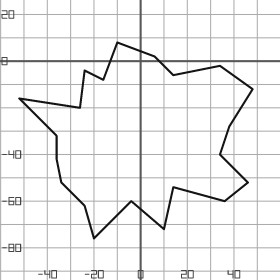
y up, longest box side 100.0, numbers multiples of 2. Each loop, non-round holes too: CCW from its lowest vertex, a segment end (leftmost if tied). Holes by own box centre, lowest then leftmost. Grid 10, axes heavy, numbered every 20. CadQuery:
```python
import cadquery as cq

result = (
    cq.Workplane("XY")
    .moveTo(-20.0, -76.0)
    .lineTo(-4.0, -60.0)
    .lineTo(10.0, -72.0)
    .lineTo(14.0, -54.0)
    .lineTo(36.0, -60.0)
    .lineTo(46.0, -52.0)
    .lineTo(34.0, -40.0)
    .lineTo(38.0, -28.0)
    .lineTo(48.0, -12.0)
    .lineTo(34.0, -2.0)
    .lineTo(14.0, -6.0)
    .lineTo(6.0, 2.0)
    .lineTo(-10.0, 8.0)
    .lineTo(-16.0, -8.0)
    .lineTo(-24.0, -4.0)
    .lineTo(-26.0, -20.0)
    .lineTo(-52.0, -16.0)
    .lineTo(-36.0, -32.0)
    .lineTo(-36.0, -42.0)
    .lineTo(-34.0, -52.0)
    .lineTo(-24.0, -62.0)
    .close()
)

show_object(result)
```